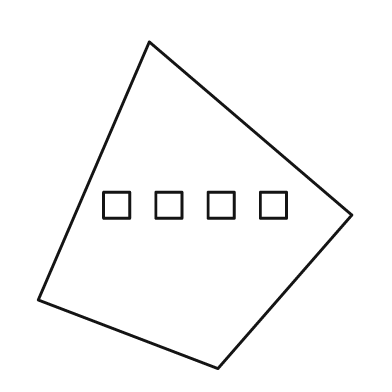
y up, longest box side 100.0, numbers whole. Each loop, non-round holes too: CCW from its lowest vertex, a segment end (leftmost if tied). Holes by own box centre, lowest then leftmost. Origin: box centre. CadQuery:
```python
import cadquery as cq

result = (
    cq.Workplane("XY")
    .moveTo(7.0, -50.0)
    .lineTo(48.0, -3.0)
    .lineTo(-14.0, 50.0)
    .lineTo(-48.0, -29.0)
    .close()
    .moveTo(-28.0, -4.0)
    .lineTo(-20.0, -4.0)
    .lineTo(-20.0, 4.0)
    .lineTo(-28.0, 4.0)
    .close()
    .moveTo(-12.0, -4.0)
    .lineTo(-4.0, -4.0)
    .lineTo(-4.0, 4.0)
    .lineTo(-12.0, 4.0)
    .close()
    .moveTo(4.0, -4.0)
    .lineTo(12.0, -4.0)
    .lineTo(12.0, 4.0)
    .lineTo(4.0, 4.0)
    .close()
    .moveTo(20.0, -4.0)
    .lineTo(28.0, -4.0)
    .lineTo(28.0, 4.0)
    .lineTo(20.0, 4.0)
    .close()
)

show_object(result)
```